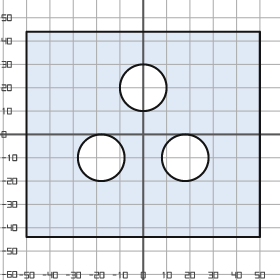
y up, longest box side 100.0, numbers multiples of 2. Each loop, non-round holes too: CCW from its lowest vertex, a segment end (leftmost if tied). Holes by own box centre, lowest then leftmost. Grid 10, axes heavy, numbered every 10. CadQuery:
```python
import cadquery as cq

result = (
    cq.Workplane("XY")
    .moveTo(-50.0, -44.0)
    .lineTo(50.0, -44.0)
    .lineTo(50.0, 44.0)
    .lineTo(-50.0, 44.0)
    .close()
    .moveTo(-18.0, -10.0)
    .circle(10.0)
    .moveTo(18.0, -10.0)
    .circle(10.0)
    .moveTo(0.0, 20.0)
    .circle(10.0)
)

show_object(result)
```